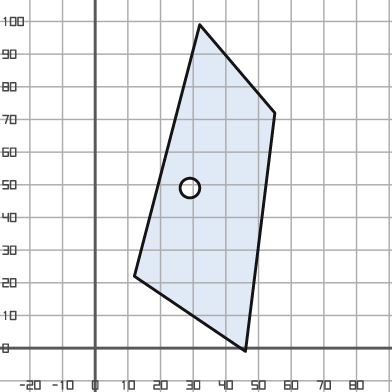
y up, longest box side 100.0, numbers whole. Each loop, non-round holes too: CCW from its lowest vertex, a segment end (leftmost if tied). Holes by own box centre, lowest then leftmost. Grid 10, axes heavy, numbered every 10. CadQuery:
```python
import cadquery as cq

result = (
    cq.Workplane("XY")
    .moveTo(46.0, -1.0)
    .lineTo(55.0, 72.0)
    .lineTo(32.0, 99.0)
    .lineTo(12.0, 22.0)
    .close()
    .moveTo(29.0, 49.0)
    .circle(3.0)
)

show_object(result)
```